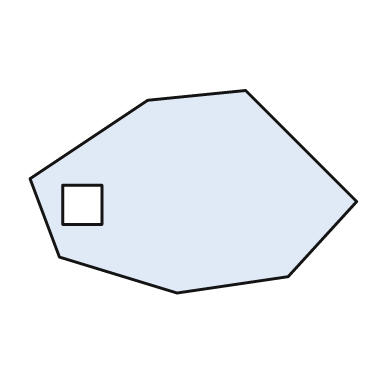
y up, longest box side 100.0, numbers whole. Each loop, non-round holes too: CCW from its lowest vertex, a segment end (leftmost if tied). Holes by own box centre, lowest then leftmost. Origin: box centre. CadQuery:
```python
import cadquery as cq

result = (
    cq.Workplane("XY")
    .moveTo(-5.0, -31.0)
    .lineTo(29.0, -26.0)
    .lineTo(50.0, -3.0)
    .lineTo(16.0, 31.0)
    .lineTo(-14.0, 28.0)
    .lineTo(-50.0, 4.0)
    .lineTo(-41.0, -20.0)
    .close()
    .moveTo(-40.0, -10.0)
    .lineTo(-28.0, -10.0)
    .lineTo(-28.0, 2.0)
    .lineTo(-40.0, 2.0)
    .close()
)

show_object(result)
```